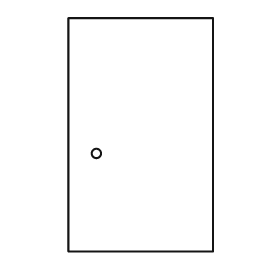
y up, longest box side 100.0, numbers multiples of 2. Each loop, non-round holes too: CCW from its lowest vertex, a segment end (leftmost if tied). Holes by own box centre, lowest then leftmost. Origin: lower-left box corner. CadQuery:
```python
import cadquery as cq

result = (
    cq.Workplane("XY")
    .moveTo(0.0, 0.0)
    .lineTo(62.0, 0.0)
    .lineTo(62.0, 100.0)
    .lineTo(0.0, 100.0)
    .close()
    .moveTo(12.0, 42.0)
    .circle(2.0)
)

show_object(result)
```